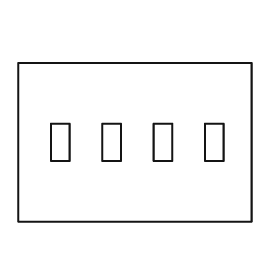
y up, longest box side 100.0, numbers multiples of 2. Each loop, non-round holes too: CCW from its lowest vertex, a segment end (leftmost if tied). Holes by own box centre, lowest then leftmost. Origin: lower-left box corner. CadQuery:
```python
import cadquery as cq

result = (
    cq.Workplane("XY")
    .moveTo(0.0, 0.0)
    .lineTo(100.0, 0.0)
    .lineTo(100.0, 68.0)
    .lineTo(0.0, 68.0)
    .close()
    .moveTo(14.0, 26.0)
    .lineTo(22.0, 26.0)
    .lineTo(22.0, 42.0)
    .lineTo(14.0, 42.0)
    .close()
    .moveTo(36.0, 26.0)
    .lineTo(44.0, 26.0)
    .lineTo(44.0, 42.0)
    .lineTo(36.0, 42.0)
    .close()
    .moveTo(58.0, 26.0)
    .lineTo(66.0, 26.0)
    .lineTo(66.0, 42.0)
    .lineTo(58.0, 42.0)
    .close()
    .moveTo(80.0, 26.0)
    .lineTo(88.0, 26.0)
    .lineTo(88.0, 42.0)
    .lineTo(80.0, 42.0)
    .close()
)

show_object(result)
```